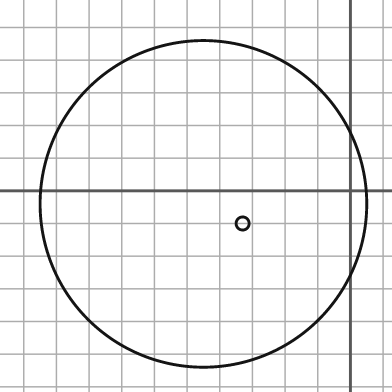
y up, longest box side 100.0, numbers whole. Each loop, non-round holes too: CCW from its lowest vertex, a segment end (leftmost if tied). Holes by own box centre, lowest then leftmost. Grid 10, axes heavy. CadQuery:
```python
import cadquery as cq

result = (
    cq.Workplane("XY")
    .moveTo(-45.0, -4.0)
    .circle(50.0)
    .moveTo(-33.0, -10.0)
    .circle(2.0)
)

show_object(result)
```